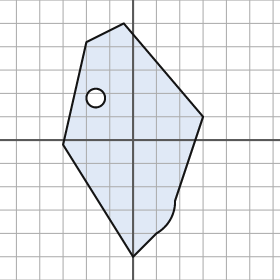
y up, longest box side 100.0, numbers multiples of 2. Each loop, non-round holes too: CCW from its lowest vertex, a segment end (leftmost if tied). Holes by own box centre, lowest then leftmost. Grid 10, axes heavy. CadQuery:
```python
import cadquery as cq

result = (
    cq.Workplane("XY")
    .moveTo(0.0, -50.0)
    .lineTo(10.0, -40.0)
    .threePointArc((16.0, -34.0), (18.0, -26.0))
    .lineTo(30.0, 10.0)
    .lineTo(-4.0, 50.0)
    .lineTo(-20.0, 42.0)
    .lineTo(-30.0, -2.0)
    .close()
    .moveTo(-16.0, 18.0)
    .circle(4.0)
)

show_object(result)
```